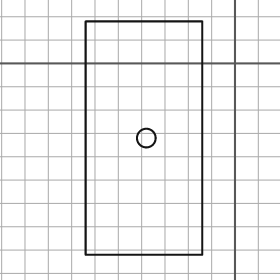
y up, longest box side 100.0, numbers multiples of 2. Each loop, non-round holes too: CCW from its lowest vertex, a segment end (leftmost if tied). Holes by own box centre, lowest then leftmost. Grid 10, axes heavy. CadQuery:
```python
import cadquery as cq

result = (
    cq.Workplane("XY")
    .moveTo(-64.0, -82.0)
    .lineTo(-14.0, -82.0)
    .lineTo(-14.0, 18.0)
    .lineTo(-64.0, 18.0)
    .close()
    .moveTo(-38.0, -32.0)
    .circle(4.0)
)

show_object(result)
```